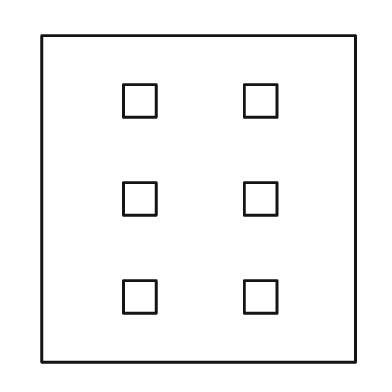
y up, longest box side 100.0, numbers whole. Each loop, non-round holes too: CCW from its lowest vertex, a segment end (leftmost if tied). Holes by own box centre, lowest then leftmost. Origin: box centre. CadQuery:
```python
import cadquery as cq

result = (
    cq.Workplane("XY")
    .moveTo(-48.0, -50.0)
    .lineTo(48.0, -50.0)
    .lineTo(48.0, 50.0)
    .lineTo(-48.0, 50.0)
    .close()
    .moveTo(-23.0, -35.0)
    .lineTo(-13.0, -35.0)
    .lineTo(-13.0, -25.0)
    .lineTo(-23.0, -25.0)
    .close()
    .moveTo(14.0, -35.0)
    .lineTo(24.0, -35.0)
    .lineTo(24.0, -25.0)
    .lineTo(14.0, -25.0)
    .close()
    .moveTo(-23.0, -5.0)
    .lineTo(-13.0, -5.0)
    .lineTo(-13.0, 5.0)
    .lineTo(-23.0, 5.0)
    .close()
    .moveTo(14.0, -5.0)
    .lineTo(24.0, -5.0)
    .lineTo(24.0, 5.0)
    .lineTo(14.0, 5.0)
    .close()
    .moveTo(-23.0, 25.0)
    .lineTo(-13.0, 25.0)
    .lineTo(-13.0, 35.0)
    .lineTo(-23.0, 35.0)
    .close()
    .moveTo(14.0, 25.0)
    .lineTo(24.0, 25.0)
    .lineTo(24.0, 35.0)
    .lineTo(14.0, 35.0)
    .close()
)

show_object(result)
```